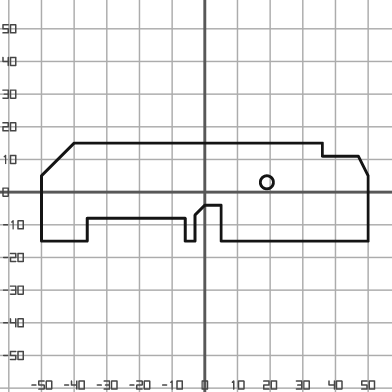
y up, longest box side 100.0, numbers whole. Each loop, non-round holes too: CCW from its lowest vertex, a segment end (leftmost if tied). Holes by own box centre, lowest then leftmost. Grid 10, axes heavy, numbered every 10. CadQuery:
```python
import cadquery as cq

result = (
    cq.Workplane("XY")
    .moveTo(-50.0, -15.0)
    .lineTo(-36.0, -15.0)
    .lineTo(-36.0, -8.0)
    .lineTo(-6.0, -8.0)
    .lineTo(-6.0, -15.0)
    .lineTo(-3.0, -15.0)
    .lineTo(-3.0, -7.0)
    .lineTo(0.0, -4.0)
    .lineTo(5.0, -4.0)
    .lineTo(5.0, -15.0)
    .lineTo(50.0, -15.0)
    .lineTo(50.0, 5.0)
    .lineTo(47.0, 11.0)
    .lineTo(36.0, 11.0)
    .lineTo(36.0, 15.0)
    .lineTo(-40.0, 15.0)
    .lineTo(-50.0, 5.0)
    .close()
    .moveTo(19.0, 3.0)
    .circle(2.0)
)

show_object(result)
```